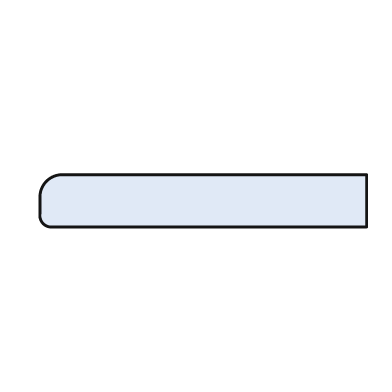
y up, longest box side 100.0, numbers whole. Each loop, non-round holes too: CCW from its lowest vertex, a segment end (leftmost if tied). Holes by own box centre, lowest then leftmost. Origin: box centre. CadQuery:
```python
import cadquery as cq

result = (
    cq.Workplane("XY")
    .moveTo(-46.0, -8.0)
    .lineTo(50.0, -8.0)
    .lineTo(50.0, 8.0)
    .lineTo(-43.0, 8.0)
    .threePointArc((-48.0, 6.0), (-50.0, 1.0))
    .lineTo(-50.0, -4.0)
    .threePointArc((-49.0, -7.0), (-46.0, -8.0))
    .close()
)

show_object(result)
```